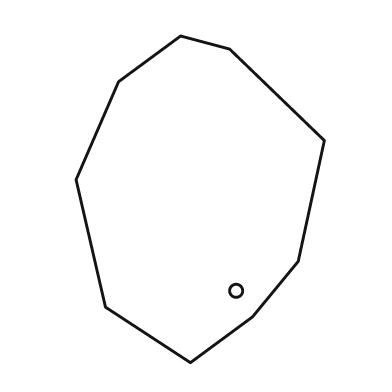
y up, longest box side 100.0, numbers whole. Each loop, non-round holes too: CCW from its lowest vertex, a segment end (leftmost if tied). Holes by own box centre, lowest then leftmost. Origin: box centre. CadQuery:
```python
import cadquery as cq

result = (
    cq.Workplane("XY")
    .moveTo(-3.0, -50.0)
    .lineTo(16.0, -36.0)
    .lineTo(30.0, -19.0)
    .lineTo(38.0, 18.0)
    .lineTo(9.0, 46.0)
    .lineTo(-6.0, 50.0)
    .lineTo(-25.0, 36.0)
    .lineTo(-38.0, 6.0)
    .lineTo(-29.0, -33.0)
    .close()
    .moveTo(11.0, -28.0)
    .circle(2.0)
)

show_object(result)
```